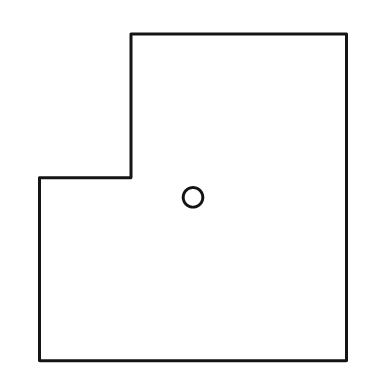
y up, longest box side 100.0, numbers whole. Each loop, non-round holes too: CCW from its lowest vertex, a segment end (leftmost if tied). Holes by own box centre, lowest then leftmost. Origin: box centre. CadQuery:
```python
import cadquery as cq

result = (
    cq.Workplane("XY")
    .moveTo(-47.0, -50.0)
    .lineTo(47.0, -50.0)
    .lineTo(47.0, 50.0)
    .lineTo(-19.0, 50.0)
    .lineTo(-19.0, 6.0)
    .lineTo(-47.0, 6.0)
    .close()
    .moveTo(0.0, 0.0)
    .circle(3.0)
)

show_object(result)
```